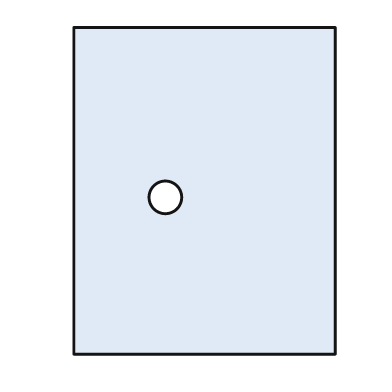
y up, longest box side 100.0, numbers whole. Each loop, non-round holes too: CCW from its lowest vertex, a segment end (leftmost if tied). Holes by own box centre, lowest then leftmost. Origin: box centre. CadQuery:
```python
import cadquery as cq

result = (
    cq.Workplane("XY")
    .moveTo(-40.0, -50.0)
    .lineTo(40.0, -50.0)
    .lineTo(40.0, 50.0)
    .lineTo(-40.0, 50.0)
    .close()
    .moveTo(-12.0, -2.0)
    .circle(5.0)
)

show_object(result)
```